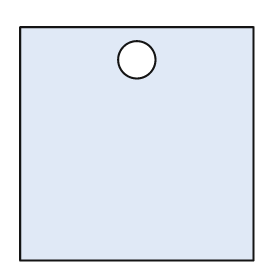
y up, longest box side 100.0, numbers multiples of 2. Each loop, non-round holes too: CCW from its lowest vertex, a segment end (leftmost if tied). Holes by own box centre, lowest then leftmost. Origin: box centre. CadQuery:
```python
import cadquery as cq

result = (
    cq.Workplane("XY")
    .moveTo(-50.0, -50.0)
    .lineTo(50.0, -50.0)
    .lineTo(50.0, 50.0)
    .lineTo(-50.0, 50.0)
    .close()
    .moveTo(0.0, 36.0)
    .circle(8.0)
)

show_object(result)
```